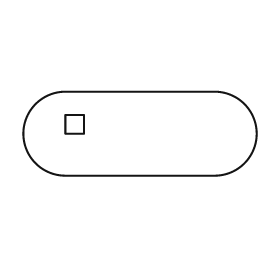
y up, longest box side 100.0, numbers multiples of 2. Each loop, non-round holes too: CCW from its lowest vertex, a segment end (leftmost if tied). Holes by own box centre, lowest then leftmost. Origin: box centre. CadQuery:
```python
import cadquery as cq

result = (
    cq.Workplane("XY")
    .moveTo(-32.0, -18.0)
    .lineTo(32.0, -18.0)
    .threePointArc((50.0, 0.0), (32.0, 18.0))
    .lineTo(-32.0, 18.0)
    .threePointArc((-50.0, 0.0), (-32.0, -18.0))
    .close()
    .moveTo(-32.0, 0.0)
    .lineTo(-24.0, 0.0)
    .lineTo(-24.0, 8.0)
    .lineTo(-32.0, 8.0)
    .close()
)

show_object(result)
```